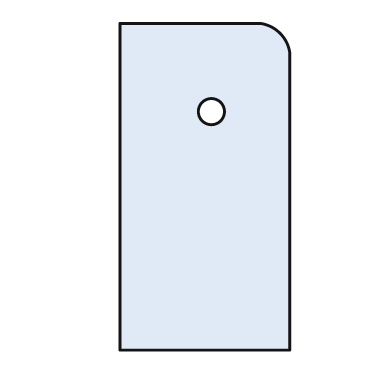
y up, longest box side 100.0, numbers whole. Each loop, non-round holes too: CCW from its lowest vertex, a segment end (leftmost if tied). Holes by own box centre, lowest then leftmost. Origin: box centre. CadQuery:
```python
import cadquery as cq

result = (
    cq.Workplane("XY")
    .moveTo(-26.0, -50.0)
    .lineTo(26.0, -50.0)
    .lineTo(26.0, 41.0)
    .threePointArc((23.0, 47.0), (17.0, 50.0))
    .lineTo(-26.0, 50.0)
    .close()
    .moveTo(2.0, 23.0)
    .circle(4.0)
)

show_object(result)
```